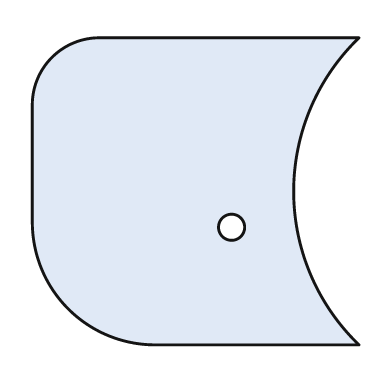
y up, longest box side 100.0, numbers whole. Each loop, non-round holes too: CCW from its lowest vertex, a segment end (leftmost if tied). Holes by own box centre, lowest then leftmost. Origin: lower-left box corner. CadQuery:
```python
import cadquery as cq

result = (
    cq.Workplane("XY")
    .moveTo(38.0, 0.0)
    .lineTo(100.0, 0.0)
    .threePointArc((80.0, 47.0), (100.0, 94.0))
    .lineTo(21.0, 94.0)
    .threePointArc((6.0, 88.0), (0.0, 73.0))
    .lineTo(0.0, 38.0)
    .threePointArc((11.0, 11.0), (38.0, 0.0))
    .close()
    .moveTo(61.0, 36.0)
    .circle(4.0)
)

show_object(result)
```